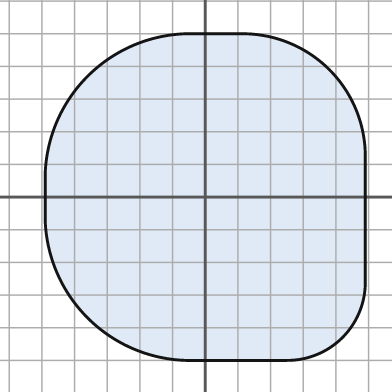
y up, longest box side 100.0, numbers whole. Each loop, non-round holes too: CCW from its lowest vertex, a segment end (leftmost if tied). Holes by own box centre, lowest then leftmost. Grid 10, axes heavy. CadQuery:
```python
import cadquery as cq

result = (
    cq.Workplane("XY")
    .moveTo(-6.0, -50.0)
    .lineTo(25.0, -50.0)
    .threePointArc((42.0, -43.0), (49.0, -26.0))
    .lineTo(49.0, 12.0)
    .threePointArc((38.0, 39.0), (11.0, 50.0))
    .lineTo(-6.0, 50.0)
    .threePointArc((-36.0, 37.0), (-49.0, 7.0))
    .lineTo(-49.0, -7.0)
    .threePointArc((-36.0, -37.0), (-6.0, -50.0))
    .close()
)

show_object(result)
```